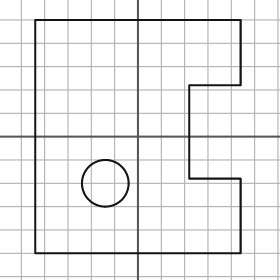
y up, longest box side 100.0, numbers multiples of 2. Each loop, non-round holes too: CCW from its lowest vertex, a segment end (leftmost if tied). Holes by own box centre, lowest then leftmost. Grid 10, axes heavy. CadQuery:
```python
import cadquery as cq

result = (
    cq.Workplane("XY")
    .moveTo(-44.0, -50.0)
    .lineTo(44.0, -50.0)
    .lineTo(44.0, -18.0)
    .lineTo(22.0, -18.0)
    .lineTo(22.0, 22.0)
    .lineTo(44.0, 22.0)
    .lineTo(44.0, 50.0)
    .lineTo(-44.0, 50.0)
    .close()
    .moveTo(-14.0, -20.0)
    .circle(10.0)
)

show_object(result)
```